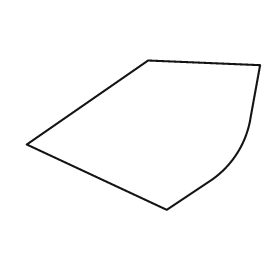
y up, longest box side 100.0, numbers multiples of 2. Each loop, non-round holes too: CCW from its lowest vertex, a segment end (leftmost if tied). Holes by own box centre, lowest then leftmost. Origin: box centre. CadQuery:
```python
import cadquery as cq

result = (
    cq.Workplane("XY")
    .moveTo(10.0, -32.0)
    .lineTo(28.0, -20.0)
    .threePointArc((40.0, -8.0), (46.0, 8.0))
    .lineTo(50.0, 30.0)
    .lineTo(2.0, 32.0)
    .lineTo(-50.0, -4.0)
    .close()
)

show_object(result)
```